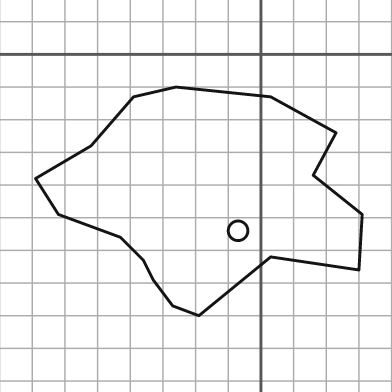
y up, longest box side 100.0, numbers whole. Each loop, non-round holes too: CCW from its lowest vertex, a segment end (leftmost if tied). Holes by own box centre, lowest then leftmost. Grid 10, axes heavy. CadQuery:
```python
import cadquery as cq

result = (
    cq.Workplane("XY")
    .moveTo(-19.0, -80.0)
    .lineTo(3.0, -62.0)
    .lineTo(30.0, -66.0)
    .lineTo(31.0, -49.0)
    .lineTo(16.0, -37.0)
    .lineTo(23.0, -24.0)
    .lineTo(3.0, -13.0)
    .lineTo(-26.0, -10.0)
    .lineTo(-39.0, -13.0)
    .lineTo(-52.0, -28.0)
    .lineTo(-69.0, -38.0)
    .lineTo(-62.0, -49.0)
    .lineTo(-43.0, -56.0)
    .lineTo(-36.0, -63.0)
    .lineTo(-33.0, -69.0)
    .lineTo(-27.0, -77.0)
    .close()
    .moveTo(-7.0, -54.0)
    .circle(3.0)
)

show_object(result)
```